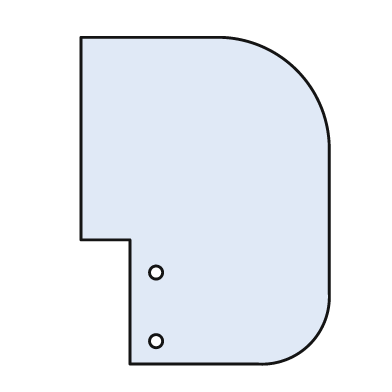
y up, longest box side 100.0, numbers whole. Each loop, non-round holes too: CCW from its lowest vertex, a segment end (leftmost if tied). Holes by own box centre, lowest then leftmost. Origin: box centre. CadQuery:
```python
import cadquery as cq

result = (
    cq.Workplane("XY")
    .moveTo(-23.0, -50.0)
    .lineTo(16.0, -50.0)
    .threePointArc((32.0, -44.0), (38.0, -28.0))
    .lineTo(38.0, 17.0)
    .threePointArc((28.0, 40.0), (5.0, 50.0))
    .lineTo(-38.0, 50.0)
    .lineTo(-38.0, -12.0)
    .lineTo(-23.0, -12.0)
    .close()
    .moveTo(-15.0, -43.0)
    .circle(2.0)
    .moveTo(-15.0, -22.0)
    .circle(2.0)
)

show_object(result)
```